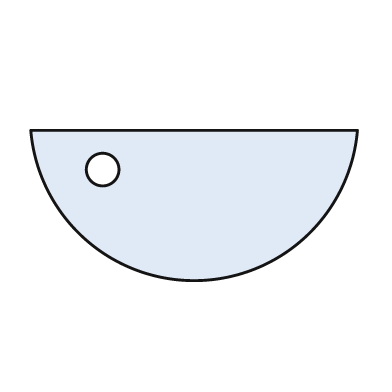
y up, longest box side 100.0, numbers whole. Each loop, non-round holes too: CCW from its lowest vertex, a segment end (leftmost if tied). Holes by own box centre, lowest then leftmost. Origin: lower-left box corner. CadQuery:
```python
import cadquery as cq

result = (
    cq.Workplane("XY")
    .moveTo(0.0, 46.0)
    .threePointArc((50.0, 0.0), (100.0, 46.0))
    .close()
    .moveTo(22.0, 34.0)
    .circle(5.0)
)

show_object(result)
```